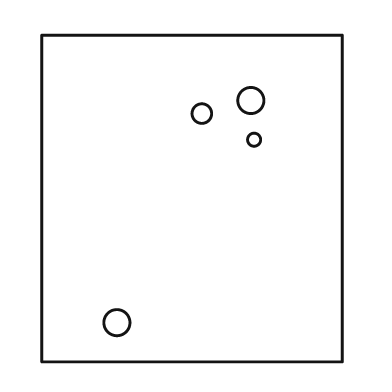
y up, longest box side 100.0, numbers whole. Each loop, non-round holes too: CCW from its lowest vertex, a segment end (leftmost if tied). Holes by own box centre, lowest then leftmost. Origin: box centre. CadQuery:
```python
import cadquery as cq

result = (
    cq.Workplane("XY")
    .moveTo(-46.0, -50.0)
    .lineTo(46.0, -50.0)
    .lineTo(46.0, 50.0)
    .lineTo(-46.0, 50.0)
    .close()
    .moveTo(-23.0, -38.0)
    .circle(4.0)
    .moveTo(19.0, 18.0)
    .circle(2.0)
    .moveTo(3.0, 26.0)
    .circle(3.0)
    .moveTo(18.0, 30.0)
    .circle(4.0)
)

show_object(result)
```